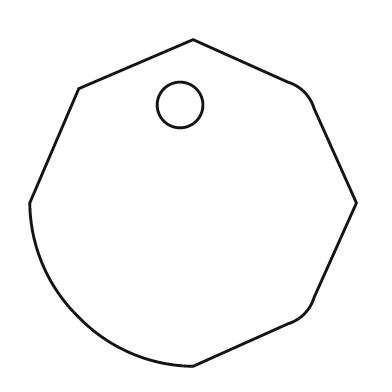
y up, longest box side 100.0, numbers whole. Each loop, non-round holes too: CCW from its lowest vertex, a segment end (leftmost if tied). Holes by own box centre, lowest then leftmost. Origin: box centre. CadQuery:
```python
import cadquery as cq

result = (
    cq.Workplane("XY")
    .moveTo(0.0, -50.0)
    .lineTo(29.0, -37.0)
    .threePointArc((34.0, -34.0), (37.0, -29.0))
    .lineTo(50.0, 0.0)
    .lineTo(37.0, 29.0)
    .threePointArc((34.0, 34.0), (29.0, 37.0))
    .lineTo(0.0, 50.0)
    .lineTo(-35.0, 35.0)
    .lineTo(-50.0, 0.0)
    .threePointArc((-46.0, -19.0), (-35.0, -35.0))
    .threePointArc((-19.0, -46.0), (0.0, -50.0))
    .close()
    .moveTo(-4.0, 30.0)
    .circle(7.0)
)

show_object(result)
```